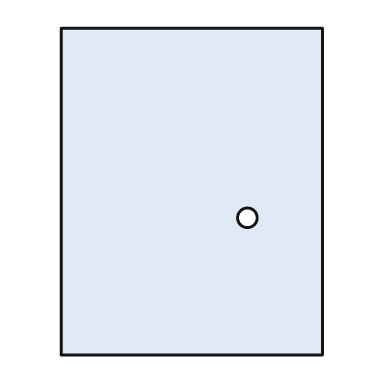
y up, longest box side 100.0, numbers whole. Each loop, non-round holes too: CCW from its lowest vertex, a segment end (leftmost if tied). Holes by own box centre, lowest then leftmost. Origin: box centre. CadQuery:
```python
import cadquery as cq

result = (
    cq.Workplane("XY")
    .moveTo(-40.0, -50.0)
    .lineTo(40.0, -50.0)
    .lineTo(40.0, 50.0)
    .lineTo(-40.0, 50.0)
    .close()
    .moveTo(17.0, -8.0)
    .circle(3.0)
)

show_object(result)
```